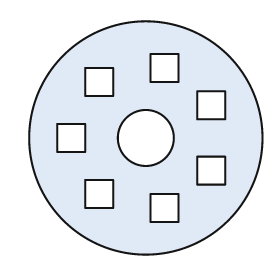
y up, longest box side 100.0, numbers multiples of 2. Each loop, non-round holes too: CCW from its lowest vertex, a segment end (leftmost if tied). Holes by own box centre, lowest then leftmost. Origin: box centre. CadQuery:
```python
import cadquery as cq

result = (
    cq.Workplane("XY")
    .moveTo(0.0, 0.0)
    .circle(50.0)
    .moveTo(2.0, -36.0)
    .lineTo(14.0, -36.0)
    .lineTo(14.0, -24.0)
    .lineTo(2.0, -24.0)
    .close()
    .moveTo(-26.0, -30.0)
    .lineTo(-14.0, -30.0)
    .lineTo(-14.0, -18.0)
    .lineTo(-26.0, -18.0)
    .close()
    .moveTo(22.0, -20.0)
    .lineTo(34.0, -20.0)
    .lineTo(34.0, -8.0)
    .lineTo(22.0, -8.0)
    .close()
    .moveTo(-38.0, -6.0)
    .lineTo(-26.0, -6.0)
    .lineTo(-26.0, 6.0)
    .lineTo(-38.0, 6.0)
    .close()
    .moveTo(0.0, 0.0)
    .circle(12.0)
    .moveTo(22.0, 8.0)
    .lineTo(34.0, 8.0)
    .lineTo(34.0, 20.0)
    .lineTo(22.0, 20.0)
    .close()
    .moveTo(-26.0, 18.0)
    .lineTo(-14.0, 18.0)
    .lineTo(-14.0, 30.0)
    .lineTo(-26.0, 30.0)
    .close()
    .moveTo(2.0, 24.0)
    .lineTo(14.0, 24.0)
    .lineTo(14.0, 36.0)
    .lineTo(2.0, 36.0)
    .close()
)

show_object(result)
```